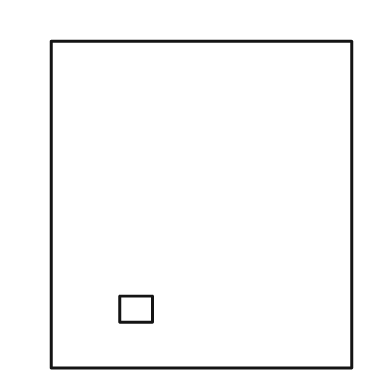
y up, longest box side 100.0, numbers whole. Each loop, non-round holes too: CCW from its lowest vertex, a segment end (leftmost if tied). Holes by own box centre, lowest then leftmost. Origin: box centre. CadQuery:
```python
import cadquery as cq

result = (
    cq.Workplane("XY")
    .moveTo(-46.0, -50.0)
    .lineTo(46.0, -50.0)
    .lineTo(46.0, 50.0)
    .lineTo(-46.0, 50.0)
    .close()
    .moveTo(-25.0, -36.0)
    .lineTo(-15.0, -36.0)
    .lineTo(-15.0, -28.0)
    .lineTo(-25.0, -28.0)
    .close()
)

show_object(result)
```